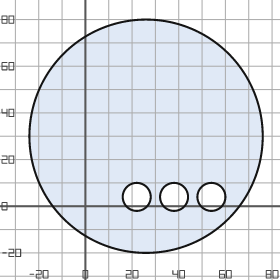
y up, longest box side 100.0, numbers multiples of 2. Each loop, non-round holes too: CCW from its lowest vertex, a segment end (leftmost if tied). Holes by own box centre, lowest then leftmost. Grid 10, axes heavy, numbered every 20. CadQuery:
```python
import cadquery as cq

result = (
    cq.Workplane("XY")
    .moveTo(26.0, 30.0)
    .circle(50.0)
    .moveTo(22.0, 4.0)
    .circle(6.0)
    .moveTo(38.0, 4.0)
    .circle(6.0)
    .moveTo(54.0, 4.0)
    .circle(6.0)
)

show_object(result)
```